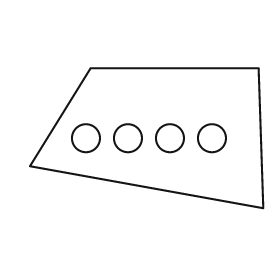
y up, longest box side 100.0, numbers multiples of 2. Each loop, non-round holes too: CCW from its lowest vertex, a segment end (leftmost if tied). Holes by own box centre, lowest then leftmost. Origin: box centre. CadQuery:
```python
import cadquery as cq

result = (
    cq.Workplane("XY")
    .moveTo(50.0, -30.0)
    .lineTo(48.0, 30.0)
    .lineTo(-24.0, 30.0)
    .lineTo(-50.0, -12.0)
    .close()
    .moveTo(-26.0, 0.0)
    .circle(6.0)
    .moveTo(-8.0, 0.0)
    .circle(6.0)
    .moveTo(10.0, 0.0)
    .circle(6.0)
    .moveTo(28.0, 0.0)
    .circle(6.0)
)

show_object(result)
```